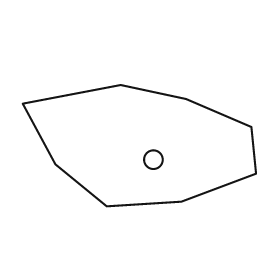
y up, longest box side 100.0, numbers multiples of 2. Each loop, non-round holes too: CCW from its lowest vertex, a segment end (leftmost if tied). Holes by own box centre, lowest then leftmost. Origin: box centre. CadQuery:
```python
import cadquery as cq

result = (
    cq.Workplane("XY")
    .moveTo(-14.0, -26.0)
    .lineTo(18.0, -24.0)
    .lineTo(50.0, -12.0)
    .lineTo(48.0, 8.0)
    .lineTo(20.0, 20.0)
    .lineTo(-8.0, 26.0)
    .lineTo(-50.0, 18.0)
    .lineTo(-36.0, -8.0)
    .close()
    .moveTo(6.0, -6.0)
    .circle(4.0)
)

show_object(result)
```